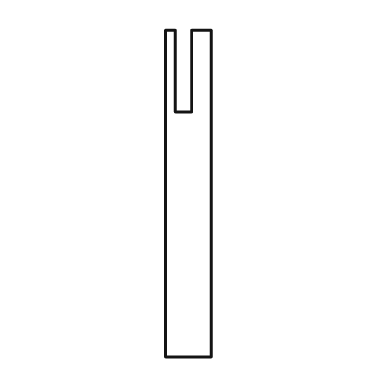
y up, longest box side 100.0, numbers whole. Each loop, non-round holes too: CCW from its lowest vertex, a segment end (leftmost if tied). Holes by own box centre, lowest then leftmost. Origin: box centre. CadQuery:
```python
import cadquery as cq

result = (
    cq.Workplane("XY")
    .moveTo(-7.0, -50.0)
    .lineTo(7.0, -50.0)
    .lineTo(7.0, 50.0)
    .lineTo(1.0, 50.0)
    .lineTo(1.0, 25.0)
    .lineTo(-4.0, 25.0)
    .lineTo(-4.0, 50.0)
    .lineTo(-7.0, 50.0)
    .close()
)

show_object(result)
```